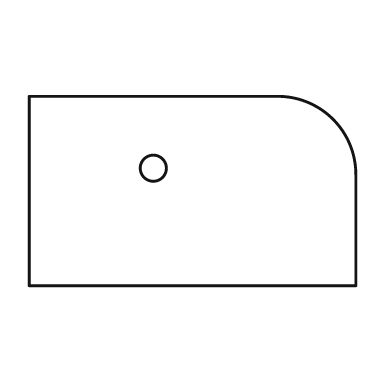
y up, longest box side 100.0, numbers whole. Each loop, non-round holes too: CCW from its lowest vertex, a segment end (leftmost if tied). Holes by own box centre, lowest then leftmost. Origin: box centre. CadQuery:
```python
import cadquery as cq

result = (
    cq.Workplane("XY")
    .moveTo(-50.0, -29.0)
    .lineTo(50.0, -29.0)
    .lineTo(50.0, 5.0)
    .threePointArc((43.0, 22.0), (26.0, 29.0))
    .lineTo(-50.0, 29.0)
    .close()
    .moveTo(-12.0, 7.0)
    .circle(4.0)
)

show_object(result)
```